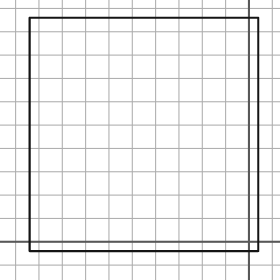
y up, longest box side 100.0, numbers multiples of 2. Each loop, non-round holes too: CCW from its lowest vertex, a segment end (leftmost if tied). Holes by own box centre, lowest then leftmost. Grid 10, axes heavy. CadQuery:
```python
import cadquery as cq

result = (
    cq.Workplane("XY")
    .moveTo(-94.0, -4.0)
    .lineTo(4.0, -4.0)
    .lineTo(4.0, 96.0)
    .lineTo(-94.0, 96.0)
    .close()
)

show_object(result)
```